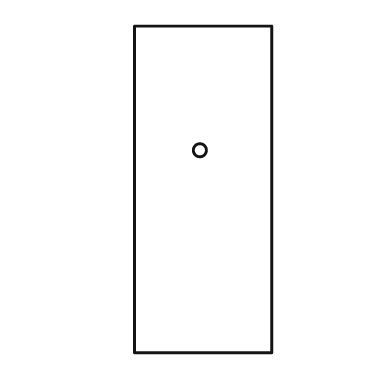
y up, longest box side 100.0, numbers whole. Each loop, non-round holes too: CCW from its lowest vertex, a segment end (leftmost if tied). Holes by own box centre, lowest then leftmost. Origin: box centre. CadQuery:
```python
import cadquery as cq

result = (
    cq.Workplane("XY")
    .moveTo(-21.0, -50.0)
    .lineTo(21.0, -50.0)
    .lineTo(21.0, 50.0)
    .lineTo(-21.0, 50.0)
    .close()
    .moveTo(-1.0, 12.0)
    .circle(2.0)
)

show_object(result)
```